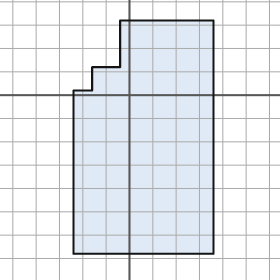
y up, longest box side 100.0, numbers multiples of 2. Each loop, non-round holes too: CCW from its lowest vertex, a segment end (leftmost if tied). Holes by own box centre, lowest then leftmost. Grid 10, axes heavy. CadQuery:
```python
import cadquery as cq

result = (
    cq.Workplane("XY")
    .moveTo(-24.0, -68.0)
    .lineTo(36.0, -68.0)
    .lineTo(36.0, 32.0)
    .lineTo(-4.0, 32.0)
    .lineTo(-4.0, 12.0)
    .lineTo(-16.0, 12.0)
    .lineTo(-16.0, 2.0)
    .lineTo(-24.0, 2.0)
    .close()
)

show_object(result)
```